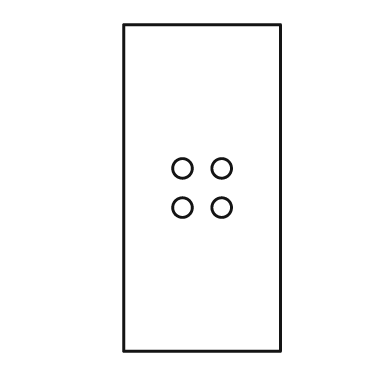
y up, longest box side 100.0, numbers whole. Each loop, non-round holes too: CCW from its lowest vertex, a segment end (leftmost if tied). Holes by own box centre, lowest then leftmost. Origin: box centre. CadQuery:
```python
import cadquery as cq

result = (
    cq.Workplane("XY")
    .moveTo(-24.0, -50.0)
    .lineTo(24.0, -50.0)
    .lineTo(24.0, 50.0)
    .lineTo(-24.0, 50.0)
    .close()
    .moveTo(-6.0, -6.0)
    .circle(3.0)
    .moveTo(6.0, -6.0)
    .circle(3.0)
    .moveTo(-6.0, 6.0)
    .circle(3.0)
    .moveTo(6.0, 6.0)
    .circle(3.0)
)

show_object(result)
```